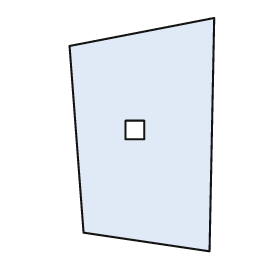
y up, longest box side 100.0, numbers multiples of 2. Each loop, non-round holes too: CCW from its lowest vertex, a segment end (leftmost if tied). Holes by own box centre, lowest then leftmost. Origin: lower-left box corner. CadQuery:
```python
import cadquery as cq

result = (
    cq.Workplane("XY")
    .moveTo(60.0, 0.0)
    .lineTo(62.0, 100.0)
    .lineTo(0.0, 88.0)
    .lineTo(6.0, 8.0)
    .close()
    .moveTo(24.0, 48.0)
    .lineTo(32.0, 48.0)
    .lineTo(32.0, 56.0)
    .lineTo(24.0, 56.0)
    .close()
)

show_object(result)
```